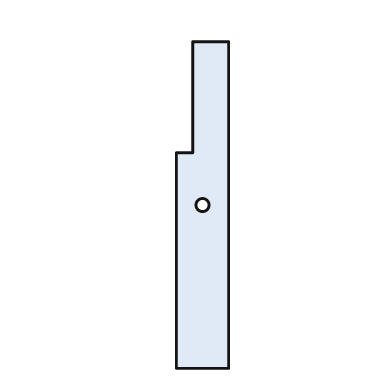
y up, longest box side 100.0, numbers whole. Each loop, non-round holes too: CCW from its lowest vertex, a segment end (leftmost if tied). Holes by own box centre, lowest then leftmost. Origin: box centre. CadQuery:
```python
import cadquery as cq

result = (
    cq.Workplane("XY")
    .moveTo(-8.0, -50.0)
    .lineTo(8.0, -50.0)
    .lineTo(8.0, 50.0)
    .lineTo(-3.0, 50.0)
    .lineTo(-3.0, 16.0)
    .lineTo(-8.0, 16.0)
    .close()
    .moveTo(0.0, 0.0)
    .circle(2.0)
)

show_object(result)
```